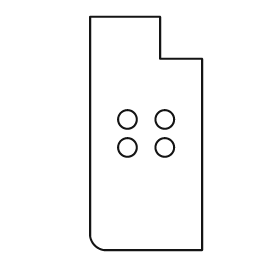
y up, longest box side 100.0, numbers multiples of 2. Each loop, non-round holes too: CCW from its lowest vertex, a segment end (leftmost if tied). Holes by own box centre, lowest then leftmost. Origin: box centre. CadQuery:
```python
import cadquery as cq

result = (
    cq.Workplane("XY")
    .moveTo(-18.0, -50.0)
    .lineTo(24.0, -50.0)
    .lineTo(24.0, 32.0)
    .lineTo(6.0, 32.0)
    .lineTo(6.0, 50.0)
    .lineTo(-24.0, 50.0)
    .lineTo(-24.0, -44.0)
    .threePointArc((-22.0, -48.0), (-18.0, -50.0))
    .close()
    .moveTo(-8.0, -6.0)
    .circle(4.0)
    .moveTo(8.0, -6.0)
    .circle(4.0)
    .moveTo(-8.0, 6.0)
    .circle(4.0)
    .moveTo(8.0, 6.0)
    .circle(4.0)
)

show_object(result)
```